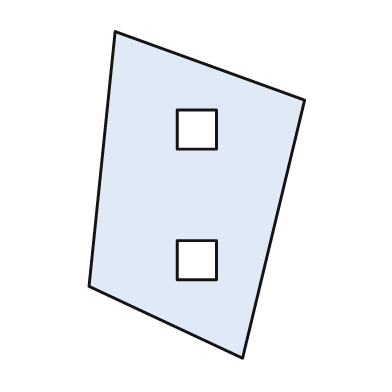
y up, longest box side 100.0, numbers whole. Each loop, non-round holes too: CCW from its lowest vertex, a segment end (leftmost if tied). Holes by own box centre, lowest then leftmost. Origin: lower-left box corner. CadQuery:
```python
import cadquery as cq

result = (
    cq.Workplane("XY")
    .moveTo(47.0, 0.0)
    .lineTo(66.0, 79.0)
    .lineTo(8.0, 100.0)
    .lineTo(0.0, 22.0)
    .close()
    .moveTo(27.0, 24.0)
    .lineTo(39.0, 24.0)
    .lineTo(39.0, 36.0)
    .lineTo(27.0, 36.0)
    .close()
    .moveTo(27.0, 64.0)
    .lineTo(39.0, 64.0)
    .lineTo(39.0, 76.0)
    .lineTo(27.0, 76.0)
    .close()
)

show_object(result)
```